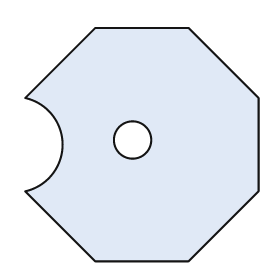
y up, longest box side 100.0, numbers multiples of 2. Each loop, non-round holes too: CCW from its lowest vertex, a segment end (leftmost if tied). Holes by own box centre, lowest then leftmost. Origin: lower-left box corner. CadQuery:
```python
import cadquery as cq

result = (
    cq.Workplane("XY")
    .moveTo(30.0, 0.0)
    .lineTo(70.0, 0.0)
    .lineTo(100.0, 30.0)
    .lineTo(100.0, 70.0)
    .lineTo(70.0, 100.0)
    .lineTo(30.0, 100.0)
    .lineTo(0.0, 70.0)
    .threePointArc((16.0, 50.0), (0.0, 30.0))
    .close()
    .moveTo(46.0, 52.0)
    .circle(8.0)
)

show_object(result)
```